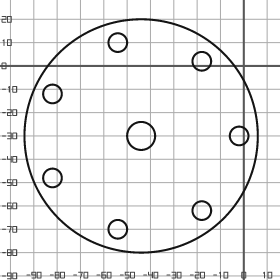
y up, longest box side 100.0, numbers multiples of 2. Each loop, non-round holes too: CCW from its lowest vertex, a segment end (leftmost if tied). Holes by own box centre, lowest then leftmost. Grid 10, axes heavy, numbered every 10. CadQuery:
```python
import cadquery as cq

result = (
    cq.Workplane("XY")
    .moveTo(-44.0, -30.0)
    .circle(50.0)
    .moveTo(-54.0, -70.0)
    .circle(4.0)
    .moveTo(-18.0, -62.0)
    .circle(4.0)
    .moveTo(-82.0, -48.0)
    .circle(4.0)
    .moveTo(-44.0, -30.0)
    .circle(6.0)
    .moveTo(-2.0, -30.0)
    .circle(4.0)
    .moveTo(-82.0, -12.0)
    .circle(4.0)
    .moveTo(-18.0, 2.0)
    .circle(4.0)
    .moveTo(-54.0, 10.0)
    .circle(4.0)
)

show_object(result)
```